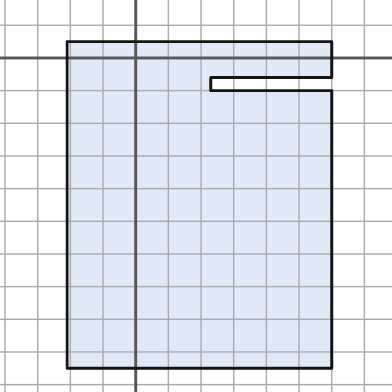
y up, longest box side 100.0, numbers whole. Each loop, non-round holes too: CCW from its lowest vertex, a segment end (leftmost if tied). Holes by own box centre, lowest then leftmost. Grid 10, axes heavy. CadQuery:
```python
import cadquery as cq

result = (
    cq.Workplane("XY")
    .moveTo(-21.0, -95.0)
    .lineTo(60.0, -95.0)
    .lineTo(60.0, -10.0)
    .lineTo(23.0, -10.0)
    .lineTo(23.0, -6.0)
    .lineTo(60.0, -6.0)
    .lineTo(60.0, 5.0)
    .lineTo(-21.0, 5.0)
    .close()
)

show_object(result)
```